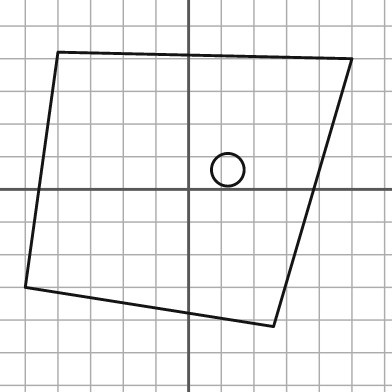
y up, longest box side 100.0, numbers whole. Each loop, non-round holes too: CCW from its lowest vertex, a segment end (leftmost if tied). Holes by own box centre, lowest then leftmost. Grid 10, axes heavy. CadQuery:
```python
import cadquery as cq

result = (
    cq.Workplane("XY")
    .moveTo(26.0, -42.0)
    .lineTo(50.0, 40.0)
    .lineTo(-40.0, 42.0)
    .lineTo(-50.0, -30.0)
    .close()
    .moveTo(12.0, 6.0)
    .circle(5.0)
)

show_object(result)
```